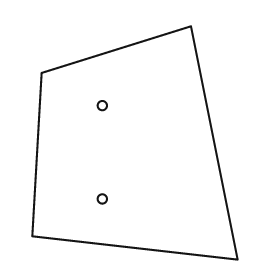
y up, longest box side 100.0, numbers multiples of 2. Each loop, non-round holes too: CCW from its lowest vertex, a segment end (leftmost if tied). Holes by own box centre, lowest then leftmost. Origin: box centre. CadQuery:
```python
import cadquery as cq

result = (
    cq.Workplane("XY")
    .moveTo(44.0, -50.0)
    .lineTo(24.0, 50.0)
    .lineTo(-40.0, 30.0)
    .lineTo(-44.0, -40.0)
    .close()
    .moveTo(-14.0, -24.0)
    .circle(2.0)
    .moveTo(-14.0, 16.0)
    .circle(2.0)
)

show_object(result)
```